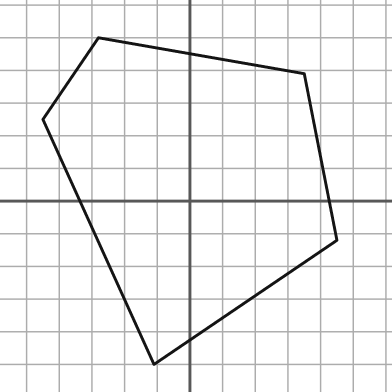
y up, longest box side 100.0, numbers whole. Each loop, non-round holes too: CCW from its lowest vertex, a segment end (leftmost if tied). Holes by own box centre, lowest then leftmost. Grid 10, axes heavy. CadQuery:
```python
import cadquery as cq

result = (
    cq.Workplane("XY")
    .moveTo(-11.0, -50.0)
    .lineTo(45.0, -12.0)
    .lineTo(35.0, 39.0)
    .lineTo(-28.0, 50.0)
    .lineTo(-45.0, 25.0)
    .close()
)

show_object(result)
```